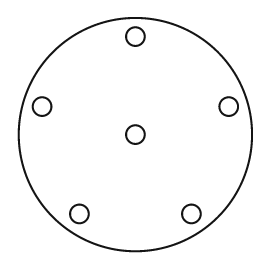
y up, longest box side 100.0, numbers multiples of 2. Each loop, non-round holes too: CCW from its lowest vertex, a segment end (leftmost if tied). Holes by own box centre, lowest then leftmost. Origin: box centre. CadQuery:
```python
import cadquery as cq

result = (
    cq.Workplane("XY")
    .moveTo(0.0, 0.0)
    .circle(50.0)
    .moveTo(-24.0, -34.0)
    .circle(4.0)
    .moveTo(24.0, -34.0)
    .circle(4.0)
    .moveTo(0.0, 0.0)
    .circle(4.0)
    .moveTo(-40.0, 12.0)
    .circle(4.0)
    .moveTo(40.0, 12.0)
    .circle(4.0)
    .moveTo(0.0, 42.0)
    .circle(4.0)
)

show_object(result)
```